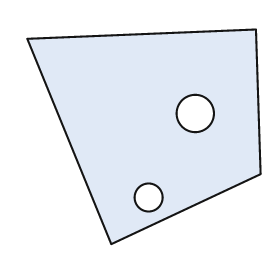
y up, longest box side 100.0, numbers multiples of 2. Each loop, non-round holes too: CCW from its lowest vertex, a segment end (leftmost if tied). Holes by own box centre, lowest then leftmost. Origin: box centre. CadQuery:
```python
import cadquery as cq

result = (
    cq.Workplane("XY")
    .moveTo(-14.0, -46.0)
    .lineTo(50.0, -16.0)
    .lineTo(48.0, 46.0)
    .lineTo(-50.0, 42.0)
    .close()
    .moveTo(2.0, -26.0)
    .circle(6.0)
    .moveTo(22.0, 10.0)
    .circle(8.0)
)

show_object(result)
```